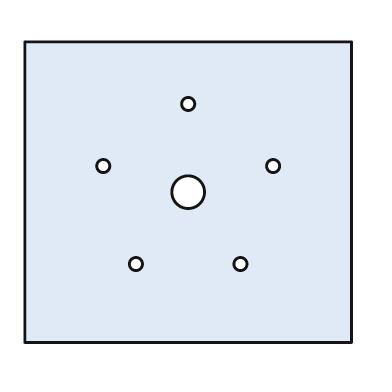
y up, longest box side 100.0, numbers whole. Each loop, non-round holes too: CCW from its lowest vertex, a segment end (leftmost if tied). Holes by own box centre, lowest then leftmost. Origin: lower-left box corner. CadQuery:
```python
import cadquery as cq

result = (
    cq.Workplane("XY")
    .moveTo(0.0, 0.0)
    .lineTo(100.0, 0.0)
    .lineTo(100.0, 92.0)
    .lineTo(0.0, 92.0)
    .close()
    .moveTo(34.0, 24.0)
    .circle(2.0)
    .moveTo(66.0, 24.0)
    .circle(2.0)
    .moveTo(50.0, 46.0)
    .circle(5.0)
    .moveTo(24.0, 54.0)
    .circle(2.0)
    .moveTo(76.0, 54.0)
    .circle(2.0)
    .moveTo(50.0, 73.0)
    .circle(2.0)
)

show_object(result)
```